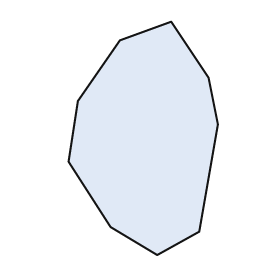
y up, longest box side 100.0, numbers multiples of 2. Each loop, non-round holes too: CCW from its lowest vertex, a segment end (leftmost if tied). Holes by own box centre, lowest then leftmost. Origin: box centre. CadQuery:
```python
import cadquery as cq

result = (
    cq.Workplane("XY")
    .moveTo(6.0, -50.0)
    .lineTo(24.0, -40.0)
    .lineTo(32.0, 6.0)
    .lineTo(28.0, 26.0)
    .lineTo(12.0, 50.0)
    .lineTo(-10.0, 42.0)
    .lineTo(-28.0, 16.0)
    .lineTo(-32.0, -10.0)
    .lineTo(-14.0, -38.0)
    .close()
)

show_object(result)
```